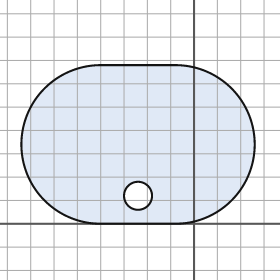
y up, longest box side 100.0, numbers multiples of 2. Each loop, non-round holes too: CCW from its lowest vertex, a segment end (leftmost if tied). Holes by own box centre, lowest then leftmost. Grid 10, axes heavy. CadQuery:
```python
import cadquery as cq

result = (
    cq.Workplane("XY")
    .moveTo(-40.0, 0.0)
    .lineTo(-8.0, 0.0)
    .threePointArc((26.0, 34.0), (-8.0, 68.0))
    .lineTo(-40.0, 68.0)
    .threePointArc((-74.0, 34.0), (-40.0, 0.0))
    .close()
    .moveTo(-24.0, 12.0)
    .circle(6.0)
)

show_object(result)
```